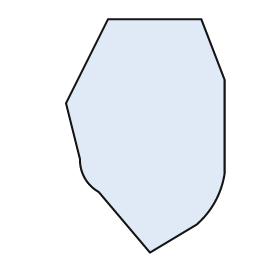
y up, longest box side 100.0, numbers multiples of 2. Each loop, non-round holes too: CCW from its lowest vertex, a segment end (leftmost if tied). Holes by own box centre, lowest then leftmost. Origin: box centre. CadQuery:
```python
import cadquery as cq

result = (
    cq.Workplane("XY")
    .moveTo(2.0, -50.0)
    .lineTo(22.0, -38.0)
    .threePointArc((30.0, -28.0), (34.0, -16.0))
    .lineTo(34.0, 24.0)
    .lineTo(24.0, 50.0)
    .lineTo(-16.0, 50.0)
    .lineTo(-34.0, 14.0)
    .lineTo(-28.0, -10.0)
    .threePointArc((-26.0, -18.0), (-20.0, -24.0))
    .close()
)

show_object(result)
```